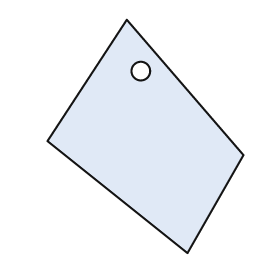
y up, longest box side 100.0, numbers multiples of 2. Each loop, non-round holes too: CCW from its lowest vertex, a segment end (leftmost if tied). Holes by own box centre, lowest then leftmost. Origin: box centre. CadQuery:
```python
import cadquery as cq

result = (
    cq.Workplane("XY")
    .moveTo(18.0, -50.0)
    .lineTo(42.0, -8.0)
    .lineTo(-8.0, 50.0)
    .lineTo(-42.0, -2.0)
    .close()
    .moveTo(-2.0, 28.0)
    .circle(4.0)
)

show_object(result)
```